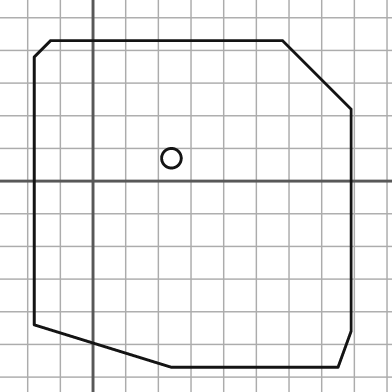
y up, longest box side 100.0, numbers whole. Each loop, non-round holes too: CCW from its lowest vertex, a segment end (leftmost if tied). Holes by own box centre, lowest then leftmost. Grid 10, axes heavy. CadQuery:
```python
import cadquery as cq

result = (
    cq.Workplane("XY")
    .moveTo(24.0, -57.0)
    .lineTo(75.0, -57.0)
    .lineTo(79.0, -46.0)
    .lineTo(79.0, 22.0)
    .lineTo(58.0, 43.0)
    .lineTo(-13.0, 43.0)
    .lineTo(-18.0, 38.0)
    .lineTo(-18.0, -44.0)
    .close()
    .moveTo(24.0, 7.0)
    .circle(3.0)
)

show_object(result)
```